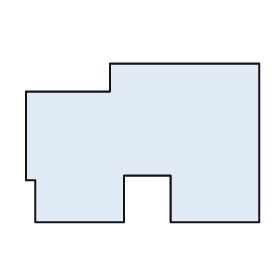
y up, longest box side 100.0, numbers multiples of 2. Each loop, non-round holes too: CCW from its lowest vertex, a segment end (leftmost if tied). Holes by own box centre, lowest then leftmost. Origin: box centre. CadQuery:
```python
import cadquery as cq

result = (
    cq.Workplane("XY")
    .moveTo(-46.0, -34.0)
    .lineTo(-8.0, -34.0)
    .lineTo(-8.0, -14.0)
    .lineTo(12.0, -14.0)
    .lineTo(12.0, -34.0)
    .lineTo(50.0, -34.0)
    .lineTo(50.0, 34.0)
    .lineTo(-14.0, 34.0)
    .lineTo(-14.0, 22.0)
    .lineTo(-50.0, 22.0)
    .lineTo(-50.0, -16.0)
    .lineTo(-46.0, -16.0)
    .close()
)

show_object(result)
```